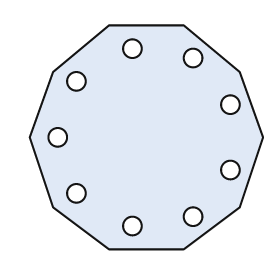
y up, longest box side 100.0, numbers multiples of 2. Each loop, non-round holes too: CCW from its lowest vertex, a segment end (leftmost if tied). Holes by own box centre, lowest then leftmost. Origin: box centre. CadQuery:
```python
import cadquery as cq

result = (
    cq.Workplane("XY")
    .moveTo(-16.0, -48.0)
    .lineTo(16.0, -48.0)
    .lineTo(40.0, -30.0)
    .lineTo(50.0, 0.0)
    .lineTo(40.0, 28.0)
    .lineTo(16.0, 48.0)
    .lineTo(-16.0, 48.0)
    .lineTo(-40.0, 28.0)
    .lineTo(-50.0, 0.0)
    .lineTo(-40.0, -30.0)
    .close()
    .moveTo(-6.0, -38.0)
    .circle(4.0)
    .moveTo(20.0, -34.0)
    .circle(4.0)
    .moveTo(-30.0, -24.0)
    .circle(4.0)
    .moveTo(36.0, -14.0)
    .circle(4.0)
    .moveTo(-38.0, 0.0)
    .circle(4.0)
    .moveTo(36.0, 14.0)
    .circle(4.0)
    .moveTo(-30.0, 24.0)
    .circle(4.0)
    .moveTo(20.0, 34.0)
    .circle(4.0)
    .moveTo(-6.0, 38.0)
    .circle(4.0)
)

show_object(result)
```